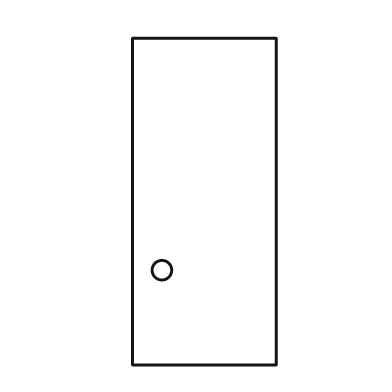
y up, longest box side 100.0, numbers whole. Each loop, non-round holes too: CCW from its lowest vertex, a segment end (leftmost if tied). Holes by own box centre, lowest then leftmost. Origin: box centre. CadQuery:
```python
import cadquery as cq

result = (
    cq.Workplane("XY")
    .moveTo(-22.0, -50.0)
    .lineTo(22.0, -50.0)
    .lineTo(22.0, 50.0)
    .lineTo(-22.0, 50.0)
    .close()
    .moveTo(-13.0, -21.0)
    .circle(3.0)
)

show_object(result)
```